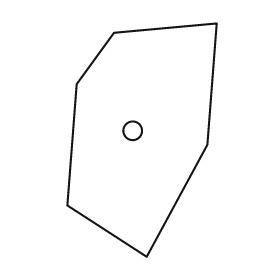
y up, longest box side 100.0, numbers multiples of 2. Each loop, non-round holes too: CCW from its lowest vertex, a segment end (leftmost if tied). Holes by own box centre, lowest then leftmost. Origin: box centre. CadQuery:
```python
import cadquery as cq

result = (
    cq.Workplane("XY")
    .moveTo(2.0, -50.0)
    .lineTo(28.0, -2.0)
    .lineTo(32.0, 50.0)
    .lineTo(-12.0, 46.0)
    .lineTo(-28.0, 24.0)
    .lineTo(-32.0, -28.0)
    .close()
    .moveTo(-4.0, 4.0)
    .circle(4.0)
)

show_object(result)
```